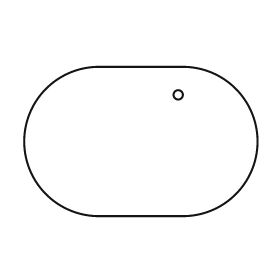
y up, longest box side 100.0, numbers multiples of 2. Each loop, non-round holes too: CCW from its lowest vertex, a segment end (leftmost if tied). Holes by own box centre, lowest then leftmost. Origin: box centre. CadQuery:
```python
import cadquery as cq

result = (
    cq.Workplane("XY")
    .moveTo(-18.0, -32.0)
    .lineTo(18.0, -32.0)
    .threePointArc((50.0, 0.0), (18.0, 32.0))
    .lineTo(-18.0, 32.0)
    .threePointArc((-50.0, 0.0), (-18.0, -32.0))
    .close()
    .moveTo(16.0, 20.0)
    .circle(2.0)
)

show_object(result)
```